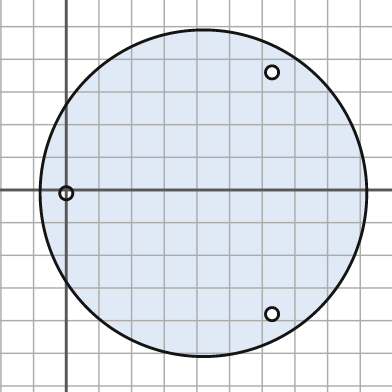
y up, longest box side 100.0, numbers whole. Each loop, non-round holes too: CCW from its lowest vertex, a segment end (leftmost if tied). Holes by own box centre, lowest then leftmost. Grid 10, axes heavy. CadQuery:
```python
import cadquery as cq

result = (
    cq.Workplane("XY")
    .moveTo(42.0, -1.0)
    .circle(50.0)
    .moveTo(63.0, -38.0)
    .circle(2.0)
    .moveTo(0.0, -1.0)
    .circle(2.0)
    .moveTo(63.0, 36.0)
    .circle(2.0)
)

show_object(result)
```